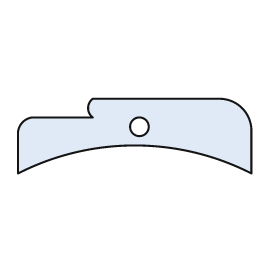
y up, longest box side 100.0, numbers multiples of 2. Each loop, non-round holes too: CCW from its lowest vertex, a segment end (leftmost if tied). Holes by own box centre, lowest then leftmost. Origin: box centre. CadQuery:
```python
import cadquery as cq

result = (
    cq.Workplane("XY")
    .moveTo(-50.0, -16.0)
    .threePointArc((0.0, -4.0), (50.0, -16.0))
    .lineTo(50.0, 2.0)
    .threePointArc((46.0, 12.0), (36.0, 16.0))
    .lineTo(-18.0, 16.0)
    .threePointArc((-20.0, 12.0), (-18.0, 8.0))
    .lineTo(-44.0, 8.0)
    .threePointArc((-48.0, 6.0), (-50.0, 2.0))
    .close()
    .moveTo(2.0, 4.0)
    .circle(4.0)
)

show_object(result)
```